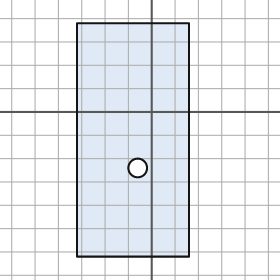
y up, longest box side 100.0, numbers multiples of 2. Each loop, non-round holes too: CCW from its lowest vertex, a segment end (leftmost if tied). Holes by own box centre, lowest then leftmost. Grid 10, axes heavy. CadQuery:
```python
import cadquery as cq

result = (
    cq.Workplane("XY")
    .moveTo(-32.0, -62.0)
    .lineTo(16.0, -62.0)
    .lineTo(16.0, 38.0)
    .lineTo(-32.0, 38.0)
    .close()
    .moveTo(-6.0, -24.0)
    .circle(4.0)
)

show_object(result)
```